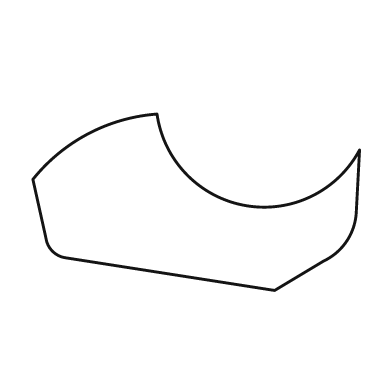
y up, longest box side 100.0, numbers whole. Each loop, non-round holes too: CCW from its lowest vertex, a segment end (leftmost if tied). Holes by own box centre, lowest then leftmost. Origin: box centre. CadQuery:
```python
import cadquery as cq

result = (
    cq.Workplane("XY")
    .moveTo(24.0, -27.0)
    .lineTo(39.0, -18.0)
    .threePointArc((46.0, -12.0), (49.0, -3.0))
    .lineTo(50.0, 16.0)
    .threePointArc((15.0, -1.0), (-12.0, 27.0))
    .threePointArc((-33.0, 21.0), (-50.0, 7.0))
    .lineTo(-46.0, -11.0)
    .threePointArc((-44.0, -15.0), (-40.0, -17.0))
    .close()
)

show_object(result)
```